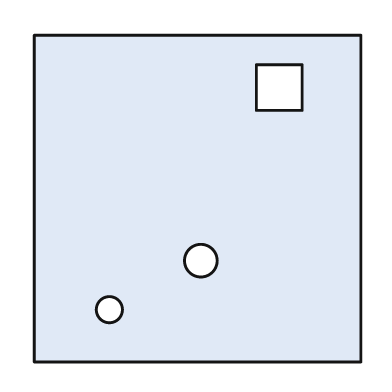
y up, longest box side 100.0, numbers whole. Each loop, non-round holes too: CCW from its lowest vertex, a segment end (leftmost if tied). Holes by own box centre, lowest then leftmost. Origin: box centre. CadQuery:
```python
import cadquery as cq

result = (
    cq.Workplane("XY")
    .moveTo(-50.0, -50.0)
    .lineTo(50.0, -50.0)
    .lineTo(50.0, 50.0)
    .lineTo(-50.0, 50.0)
    .close()
    .moveTo(-27.0, -34.0)
    .circle(4.0)
    .moveTo(1.0, -19.0)
    .circle(5.0)
    .moveTo(18.0, 27.0)
    .lineTo(32.0, 27.0)
    .lineTo(32.0, 41.0)
    .lineTo(18.0, 41.0)
    .close()
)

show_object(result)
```